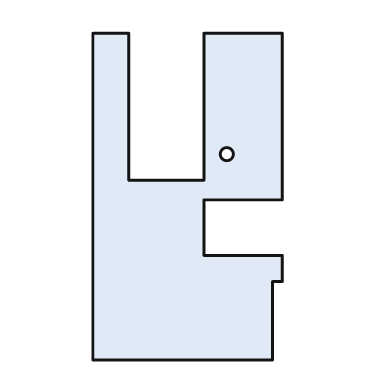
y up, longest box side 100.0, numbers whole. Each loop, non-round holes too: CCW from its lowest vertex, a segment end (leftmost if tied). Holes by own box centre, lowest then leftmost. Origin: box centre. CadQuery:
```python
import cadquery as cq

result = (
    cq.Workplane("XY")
    .moveTo(-29.0, -50.0)
    .lineTo(26.0, -50.0)
    .lineTo(26.0, -26.0)
    .lineTo(29.0, -26.0)
    .lineTo(29.0, -18.0)
    .lineTo(5.0, -18.0)
    .lineTo(5.0, -1.0)
    .lineTo(29.0, -1.0)
    .lineTo(29.0, 50.0)
    .lineTo(5.0, 50.0)
    .lineTo(5.0, 5.0)
    .lineTo(-18.0, 5.0)
    .lineTo(-18.0, 50.0)
    .lineTo(-29.0, 50.0)
    .close()
    .moveTo(12.0, 13.0)
    .circle(2.0)
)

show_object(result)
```